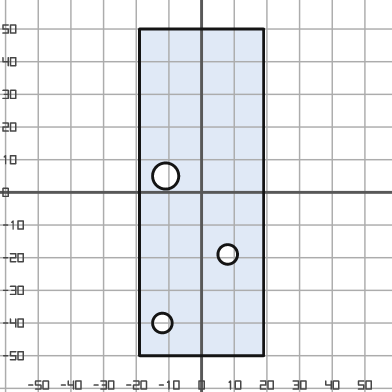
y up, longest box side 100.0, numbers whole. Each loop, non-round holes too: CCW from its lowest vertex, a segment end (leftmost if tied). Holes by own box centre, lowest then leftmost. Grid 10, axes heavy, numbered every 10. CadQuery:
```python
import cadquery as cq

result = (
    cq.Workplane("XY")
    .moveTo(-19.0, -50.0)
    .lineTo(19.0, -50.0)
    .lineTo(19.0, 50.0)
    .lineTo(-19.0, 50.0)
    .close()
    .moveTo(-12.0, -40.0)
    .circle(3.0)
    .moveTo(8.0, -19.0)
    .circle(3.0)
    .moveTo(-11.0, 5.0)
    .circle(4.0)
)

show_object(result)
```